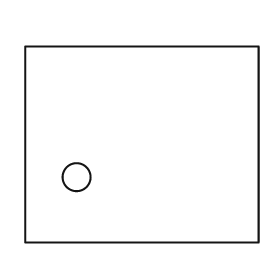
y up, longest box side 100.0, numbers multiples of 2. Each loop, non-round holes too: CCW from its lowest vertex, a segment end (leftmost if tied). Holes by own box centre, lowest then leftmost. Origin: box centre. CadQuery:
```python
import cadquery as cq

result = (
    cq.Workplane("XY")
    .moveTo(-50.0, -42.0)
    .lineTo(50.0, -42.0)
    .lineTo(50.0, 42.0)
    .lineTo(-50.0, 42.0)
    .close()
    .moveTo(-28.0, -14.0)
    .circle(6.0)
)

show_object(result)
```